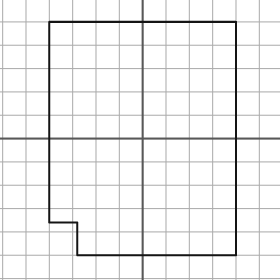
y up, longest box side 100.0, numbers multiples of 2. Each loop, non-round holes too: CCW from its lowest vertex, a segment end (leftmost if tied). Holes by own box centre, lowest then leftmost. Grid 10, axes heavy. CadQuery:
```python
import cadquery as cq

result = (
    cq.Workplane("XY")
    .moveTo(-28.0, -50.0)
    .lineTo(40.0, -50.0)
    .lineTo(40.0, 50.0)
    .lineTo(-40.0, 50.0)
    .lineTo(-40.0, -36.0)
    .lineTo(-28.0, -36.0)
    .close()
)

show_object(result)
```